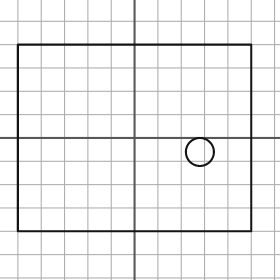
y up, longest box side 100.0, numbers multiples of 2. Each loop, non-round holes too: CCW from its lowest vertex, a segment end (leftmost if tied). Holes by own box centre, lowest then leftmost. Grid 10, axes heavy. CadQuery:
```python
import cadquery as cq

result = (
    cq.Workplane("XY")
    .moveTo(-50.0, -40.0)
    .lineTo(50.0, -40.0)
    .lineTo(50.0, 40.0)
    .lineTo(-50.0, 40.0)
    .close()
    .moveTo(28.0, -6.0)
    .circle(6.0)
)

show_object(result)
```